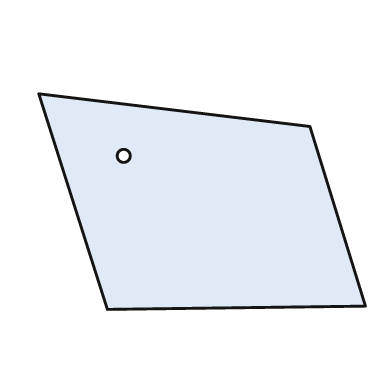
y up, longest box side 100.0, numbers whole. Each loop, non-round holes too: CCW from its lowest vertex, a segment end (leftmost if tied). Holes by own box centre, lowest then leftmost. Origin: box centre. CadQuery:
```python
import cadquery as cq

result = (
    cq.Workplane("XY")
    .moveTo(-29.0, -33.0)
    .lineTo(50.0, -32.0)
    .lineTo(33.0, 23.0)
    .lineTo(-50.0, 33.0)
    .close()
    .moveTo(-24.0, 14.0)
    .circle(2.0)
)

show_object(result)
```